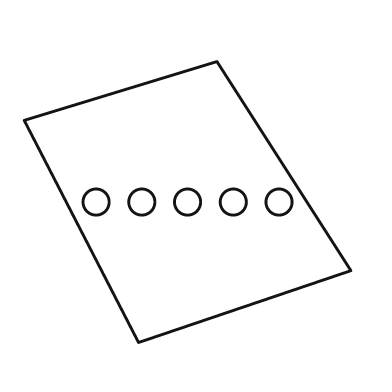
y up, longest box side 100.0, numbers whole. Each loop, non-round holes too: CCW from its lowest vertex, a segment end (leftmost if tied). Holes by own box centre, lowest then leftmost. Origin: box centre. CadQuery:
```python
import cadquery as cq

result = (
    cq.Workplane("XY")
    .moveTo(-15.0, -43.0)
    .lineTo(50.0, -21.0)
    .lineTo(9.0, 43.0)
    .lineTo(-50.0, 25.0)
    .close()
    .moveTo(-28.0, 0.0)
    .circle(4.0)
    .moveTo(-14.0, 0.0)
    .circle(4.0)
    .moveTo(0.0, 0.0)
    .circle(4.0)
    .moveTo(14.0, 0.0)
    .circle(4.0)
    .moveTo(28.0, 0.0)
    .circle(4.0)
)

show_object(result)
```